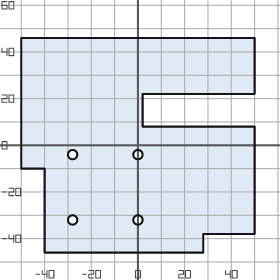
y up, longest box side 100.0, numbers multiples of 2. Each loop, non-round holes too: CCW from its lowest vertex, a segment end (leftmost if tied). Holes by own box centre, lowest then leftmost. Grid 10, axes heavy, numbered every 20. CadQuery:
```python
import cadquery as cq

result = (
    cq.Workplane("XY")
    .moveTo(-40.0, -46.0)
    .lineTo(28.0, -46.0)
    .lineTo(28.0, -38.0)
    .lineTo(50.0, -38.0)
    .lineTo(50.0, 8.0)
    .lineTo(2.0, 8.0)
    .lineTo(2.0, 22.0)
    .lineTo(50.0, 22.0)
    .lineTo(50.0, 46.0)
    .lineTo(-50.0, 46.0)
    .lineTo(-50.0, -10.0)
    .lineTo(-40.0, -10.0)
    .close()
    .moveTo(-28.0, -32.0)
    .circle(2.0)
    .moveTo(0.0, -32.0)
    .circle(2.0)
    .moveTo(-28.0, -4.0)
    .circle(2.0)
    .moveTo(0.0, -4.0)
    .circle(2.0)
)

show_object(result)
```